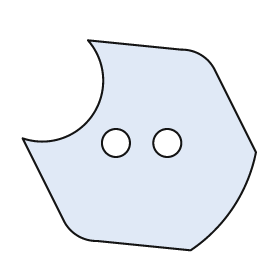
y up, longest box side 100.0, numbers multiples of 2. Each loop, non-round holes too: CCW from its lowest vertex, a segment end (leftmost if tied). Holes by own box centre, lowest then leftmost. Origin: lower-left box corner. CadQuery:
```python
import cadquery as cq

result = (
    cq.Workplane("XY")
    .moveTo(72.0, 0.0)
    .threePointArc((90.0, 18.0), (100.0, 42.0))
    .lineTo(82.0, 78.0)
    .threePointArc((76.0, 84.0), (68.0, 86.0))
    .lineTo(28.0, 90.0)
    .threePointArc((30.0, 58.0), (0.0, 48.0))
    .lineTo(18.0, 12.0)
    .threePointArc((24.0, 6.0), (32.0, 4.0))
    .close()
    .moveTo(40.0, 46.0)
    .circle(6.0)
    .moveTo(62.0, 46.0)
    .circle(6.0)
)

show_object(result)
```